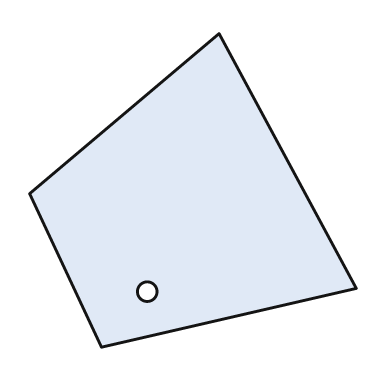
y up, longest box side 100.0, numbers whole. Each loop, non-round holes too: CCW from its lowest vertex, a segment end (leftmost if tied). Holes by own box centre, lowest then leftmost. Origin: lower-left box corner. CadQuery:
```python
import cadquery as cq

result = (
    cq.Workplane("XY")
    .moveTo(22.0, 0.0)
    .lineTo(100.0, 18.0)
    .lineTo(58.0, 96.0)
    .lineTo(0.0, 47.0)
    .close()
    .moveTo(36.0, 17.0)
    .circle(3.0)
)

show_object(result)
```